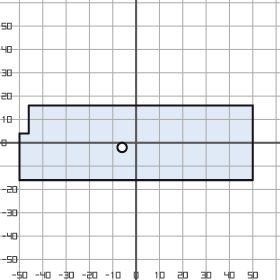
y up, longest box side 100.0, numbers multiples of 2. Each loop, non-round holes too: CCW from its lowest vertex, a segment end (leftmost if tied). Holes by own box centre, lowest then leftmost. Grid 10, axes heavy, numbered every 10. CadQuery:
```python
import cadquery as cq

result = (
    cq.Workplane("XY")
    .moveTo(-50.0, -16.0)
    .lineTo(50.0, -16.0)
    .lineTo(50.0, 16.0)
    .lineTo(-46.0, 16.0)
    .lineTo(-46.0, 4.0)
    .lineTo(-50.0, 4.0)
    .close()
    .moveTo(-6.0, -2.0)
    .circle(2.0)
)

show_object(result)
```